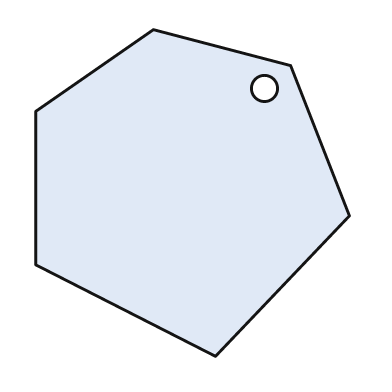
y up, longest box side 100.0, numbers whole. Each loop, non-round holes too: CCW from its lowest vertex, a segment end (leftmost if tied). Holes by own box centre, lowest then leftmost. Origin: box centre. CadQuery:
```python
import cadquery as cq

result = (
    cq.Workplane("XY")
    .moveTo(7.0, -50.0)
    .lineTo(48.0, -7.0)
    .lineTo(30.0, 39.0)
    .lineTo(-12.0, 50.0)
    .lineTo(-48.0, 25.0)
    .lineTo(-48.0, -22.0)
    .close()
    .moveTo(22.0, 32.0)
    .circle(4.0)
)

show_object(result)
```